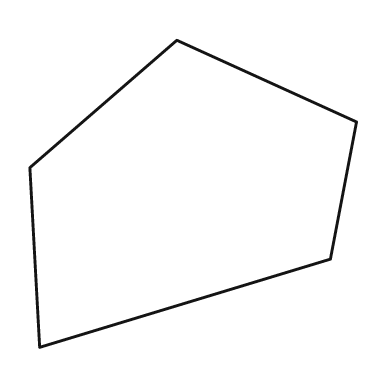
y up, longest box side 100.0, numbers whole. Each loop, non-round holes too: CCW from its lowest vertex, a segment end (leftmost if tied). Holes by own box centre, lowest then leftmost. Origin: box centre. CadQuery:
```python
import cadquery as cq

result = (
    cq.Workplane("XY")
    .moveTo(-47.0, -47.0)
    .lineTo(42.0, -20.0)
    .lineTo(50.0, 22.0)
    .lineTo(-5.0, 47.0)
    .lineTo(-50.0, 8.0)
    .close()
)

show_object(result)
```